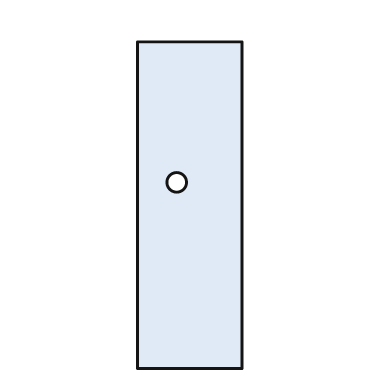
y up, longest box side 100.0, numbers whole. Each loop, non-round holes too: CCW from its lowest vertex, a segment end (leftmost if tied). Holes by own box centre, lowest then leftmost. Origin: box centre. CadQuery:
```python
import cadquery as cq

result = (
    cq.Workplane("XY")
    .moveTo(-16.0, -50.0)
    .lineTo(16.0, -50.0)
    .lineTo(16.0, 50.0)
    .lineTo(-16.0, 50.0)
    .close()
    .moveTo(-4.0, 7.0)
    .circle(3.0)
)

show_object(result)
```